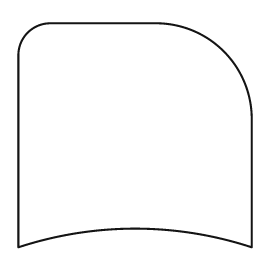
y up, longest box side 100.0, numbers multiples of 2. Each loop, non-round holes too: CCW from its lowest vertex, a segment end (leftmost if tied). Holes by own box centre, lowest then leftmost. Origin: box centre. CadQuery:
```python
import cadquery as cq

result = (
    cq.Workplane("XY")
    .moveTo(-50.0, -48.0)
    .threePointArc((0.0, -40.0), (50.0, -48.0))
    .lineTo(50.0, 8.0)
    .threePointArc((38.0, 36.0), (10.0, 48.0))
    .lineTo(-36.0, 48.0)
    .threePointArc((-46.0, 44.0), (-50.0, 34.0))
    .close()
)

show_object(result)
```